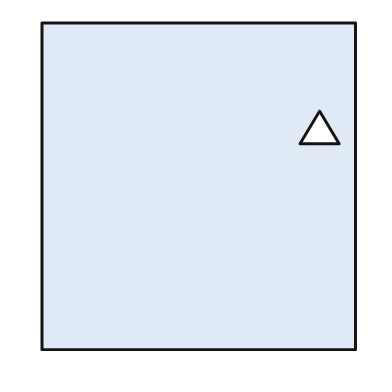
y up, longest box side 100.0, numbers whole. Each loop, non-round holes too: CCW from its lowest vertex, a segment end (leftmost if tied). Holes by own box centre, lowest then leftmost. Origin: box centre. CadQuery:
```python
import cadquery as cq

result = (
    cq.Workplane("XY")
    .moveTo(-48.0, -50.0)
    .lineTo(48.0, -50.0)
    .lineTo(48.0, 50.0)
    .lineTo(-48.0, 50.0)
    .close()
    .moveTo(31.0, 13.0)
    .lineTo(43.0, 13.0)
    .lineTo(37.0, 23.0)
    .close()
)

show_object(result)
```